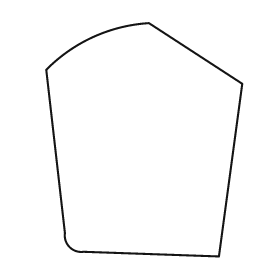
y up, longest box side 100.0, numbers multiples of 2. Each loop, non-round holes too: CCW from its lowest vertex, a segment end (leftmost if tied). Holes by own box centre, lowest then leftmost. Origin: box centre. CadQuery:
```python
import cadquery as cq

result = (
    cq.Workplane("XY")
    .moveTo(32.0, -50.0)
    .lineTo(42.0, 24.0)
    .lineTo(2.0, 50.0)
    .threePointArc((-22.0, 44.0), (-42.0, 30.0))
    .lineTo(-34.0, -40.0)
    .threePointArc((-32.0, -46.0), (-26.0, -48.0))
    .close()
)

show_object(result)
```